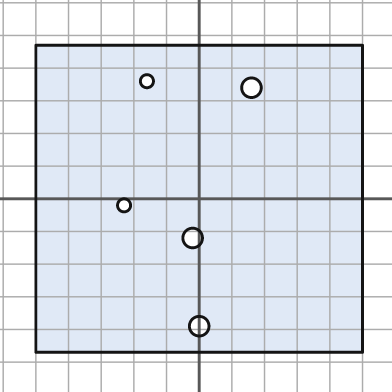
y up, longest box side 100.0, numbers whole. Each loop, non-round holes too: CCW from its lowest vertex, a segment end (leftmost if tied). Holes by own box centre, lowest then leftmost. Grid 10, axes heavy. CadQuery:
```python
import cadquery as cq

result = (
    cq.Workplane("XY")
    .moveTo(-50.0, -47.0)
    .lineTo(50.0, -47.0)
    .lineTo(50.0, 47.0)
    .lineTo(-50.0, 47.0)
    .close()
    .moveTo(0.0, -39.0)
    .circle(3.0)
    .moveTo(-2.0, -12.0)
    .circle(3.0)
    .moveTo(-23.0, -2.0)
    .circle(2.0)
    .moveTo(16.0, 34.0)
    .circle(3.0)
    .moveTo(-16.0, 36.0)
    .circle(2.0)
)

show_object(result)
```